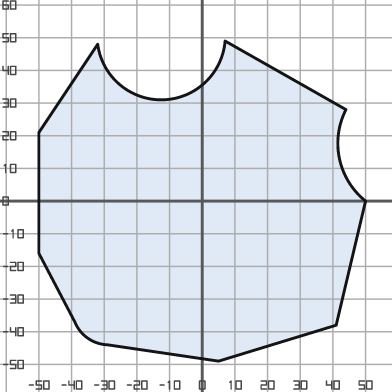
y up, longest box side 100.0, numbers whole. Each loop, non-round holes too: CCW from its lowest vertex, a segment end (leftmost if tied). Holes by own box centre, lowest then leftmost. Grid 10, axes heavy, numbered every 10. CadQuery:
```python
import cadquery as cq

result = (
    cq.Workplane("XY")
    .moveTo(5.0, -49.0)
    .lineTo(41.0, -38.0)
    .lineTo(50.0, 0.0)
    .threePointArc((42.0, 13.0), (44.0, 28.0))
    .lineTo(7.0, 49.0)
    .threePointArc((-12.0, 31.0), (-32.0, 48.0))
    .lineTo(-50.0, 21.0)
    .lineTo(-50.0, -16.0)
    .lineTo(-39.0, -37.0)
    .threePointArc((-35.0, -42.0), (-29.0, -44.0))
    .close()
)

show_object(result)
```